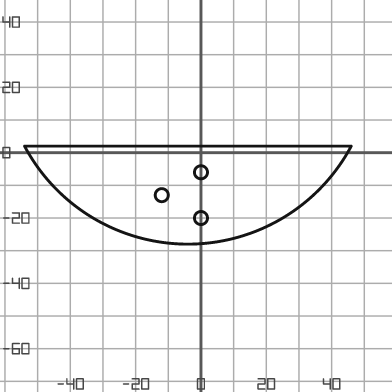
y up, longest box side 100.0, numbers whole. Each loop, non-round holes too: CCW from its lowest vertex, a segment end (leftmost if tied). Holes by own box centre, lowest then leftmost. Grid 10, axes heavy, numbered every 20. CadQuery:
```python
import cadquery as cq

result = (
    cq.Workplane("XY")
    .moveTo(-54.0, 2.0)
    .threePointArc((-4.0, -28.0), (46.0, 2.0))
    .close()
    .moveTo(0.0, -20.0)
    .circle(2.0)
    .moveTo(-12.0, -13.0)
    .circle(2.0)
    .moveTo(0.0, -6.0)
    .circle(2.0)
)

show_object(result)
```